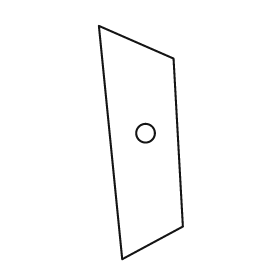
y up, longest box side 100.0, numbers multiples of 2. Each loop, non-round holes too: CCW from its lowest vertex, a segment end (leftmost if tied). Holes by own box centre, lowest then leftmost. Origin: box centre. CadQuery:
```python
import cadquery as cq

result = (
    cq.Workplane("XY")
    .moveTo(-8.0, -50.0)
    .lineTo(18.0, -36.0)
    .lineTo(14.0, 36.0)
    .lineTo(-18.0, 50.0)
    .close()
    .moveTo(2.0, 4.0)
    .circle(4.0)
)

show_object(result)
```